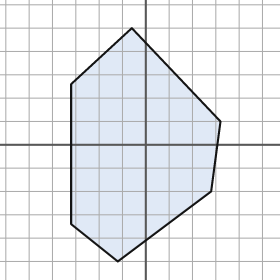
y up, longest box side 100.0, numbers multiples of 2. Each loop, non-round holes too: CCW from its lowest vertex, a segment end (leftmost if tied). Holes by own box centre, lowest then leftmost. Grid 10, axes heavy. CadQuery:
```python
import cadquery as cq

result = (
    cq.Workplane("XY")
    .moveTo(-12.0, -50.0)
    .lineTo(28.0, -20.0)
    .lineTo(32.0, 10.0)
    .lineTo(-6.0, 50.0)
    .lineTo(-32.0, 26.0)
    .lineTo(-32.0, -34.0)
    .close()
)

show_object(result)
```